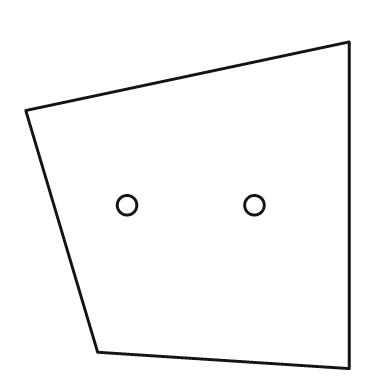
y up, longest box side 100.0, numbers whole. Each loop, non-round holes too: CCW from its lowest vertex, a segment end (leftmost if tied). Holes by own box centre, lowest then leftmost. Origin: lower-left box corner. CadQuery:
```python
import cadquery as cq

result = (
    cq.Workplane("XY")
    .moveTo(99.0, 0.0)
    .lineTo(99.0, 100.0)
    .lineTo(0.0, 79.0)
    .lineTo(22.0, 5.0)
    .close()
    .moveTo(31.0, 50.0)
    .circle(3.0)
    .moveTo(70.0, 50.0)
    .circle(3.0)
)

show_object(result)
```